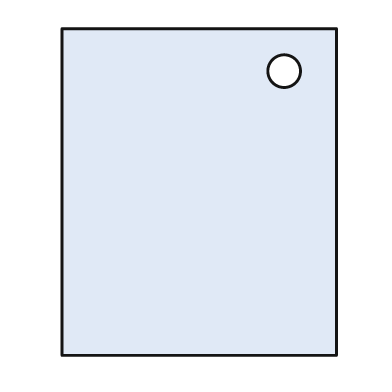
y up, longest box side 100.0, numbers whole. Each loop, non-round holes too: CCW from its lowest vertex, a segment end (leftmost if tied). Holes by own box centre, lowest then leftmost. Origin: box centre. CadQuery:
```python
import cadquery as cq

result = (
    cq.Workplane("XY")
    .moveTo(-42.0, -50.0)
    .lineTo(42.0, -50.0)
    .lineTo(42.0, 50.0)
    .lineTo(-42.0, 50.0)
    .close()
    .moveTo(26.0, 37.0)
    .circle(5.0)
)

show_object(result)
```